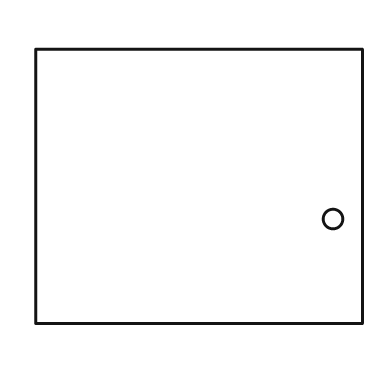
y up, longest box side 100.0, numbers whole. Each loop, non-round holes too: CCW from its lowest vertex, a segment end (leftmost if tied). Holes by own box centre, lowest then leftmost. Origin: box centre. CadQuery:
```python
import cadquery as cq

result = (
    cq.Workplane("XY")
    .moveTo(-50.0, -42.0)
    .lineTo(50.0, -42.0)
    .lineTo(50.0, 42.0)
    .lineTo(-50.0, 42.0)
    .close()
    .moveTo(41.0, -10.0)
    .circle(3.0)
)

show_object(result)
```